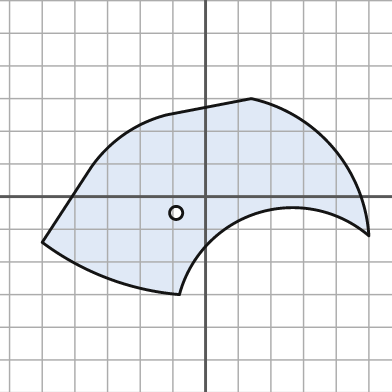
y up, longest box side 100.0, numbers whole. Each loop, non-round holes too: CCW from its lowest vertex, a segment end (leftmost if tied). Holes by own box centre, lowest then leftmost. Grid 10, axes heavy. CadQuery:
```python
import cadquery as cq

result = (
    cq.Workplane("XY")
    .moveTo(-8.0, -30.0)
    .threePointArc((16.0, -5.0), (50.0, -12.0))
    .threePointArc((39.0, 15.0), (14.0, 30.0))
    .lineTo(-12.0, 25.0)
    .threePointArc((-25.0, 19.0), (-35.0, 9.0))
    .lineTo(-50.0, -14.0)
    .threePointArc((-30.0, -25.0), (-8.0, -30.0))
    .close()
    .moveTo(-9.0, -5.0)
    .circle(2.0)
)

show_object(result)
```